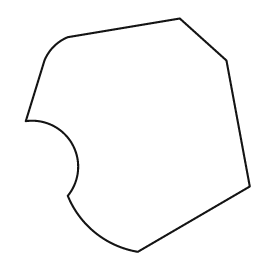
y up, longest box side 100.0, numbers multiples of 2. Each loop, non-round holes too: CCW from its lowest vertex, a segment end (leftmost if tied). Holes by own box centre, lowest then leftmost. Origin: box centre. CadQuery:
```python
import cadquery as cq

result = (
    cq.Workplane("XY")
    .moveTo(0.0, -50.0)
    .lineTo(48.0, -22.0)
    .lineTo(38.0, 32.0)
    .lineTo(18.0, 50.0)
    .lineTo(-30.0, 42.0)
    .threePointArc((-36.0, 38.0), (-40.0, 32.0))
    .lineTo(-48.0, 6.0)
    .threePointArc((-28.0, -4.0), (-30.0, -26.0))
    .threePointArc((-18.0, -42.0), (0.0, -50.0))
    .close()
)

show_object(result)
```